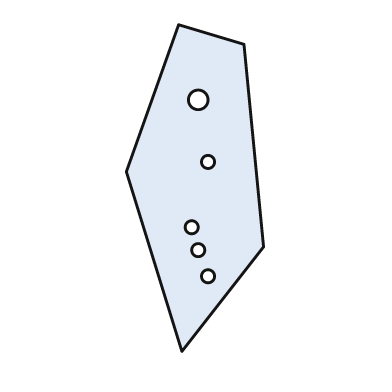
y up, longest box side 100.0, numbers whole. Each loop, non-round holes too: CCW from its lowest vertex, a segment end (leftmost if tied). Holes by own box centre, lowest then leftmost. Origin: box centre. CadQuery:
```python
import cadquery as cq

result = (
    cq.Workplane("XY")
    .moveTo(-4.0, -50.0)
    .lineTo(21.0, -18.0)
    .lineTo(15.0, 44.0)
    .lineTo(-5.0, 50.0)
    .lineTo(-21.0, 5.0)
    .close()
    .moveTo(4.0, -27.0)
    .circle(2.0)
    .moveTo(1.0, -19.0)
    .circle(2.0)
    .moveTo(-1.0, -12.0)
    .circle(2.0)
    .moveTo(4.0, 8.0)
    .circle(2.0)
    .moveTo(1.0, 27.0)
    .circle(3.0)
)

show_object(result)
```